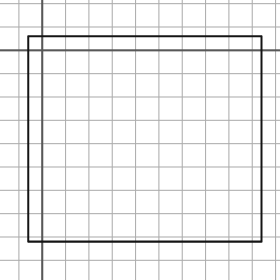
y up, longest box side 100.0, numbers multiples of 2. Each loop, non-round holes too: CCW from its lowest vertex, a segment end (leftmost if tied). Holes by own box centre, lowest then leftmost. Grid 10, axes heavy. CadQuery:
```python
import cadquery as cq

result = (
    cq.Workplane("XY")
    .moveTo(-6.0, -82.0)
    .lineTo(94.0, -82.0)
    .lineTo(94.0, 6.0)
    .lineTo(-6.0, 6.0)
    .close()
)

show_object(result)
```